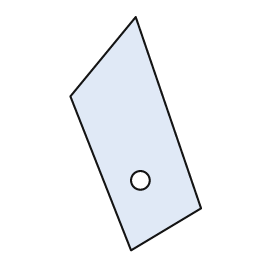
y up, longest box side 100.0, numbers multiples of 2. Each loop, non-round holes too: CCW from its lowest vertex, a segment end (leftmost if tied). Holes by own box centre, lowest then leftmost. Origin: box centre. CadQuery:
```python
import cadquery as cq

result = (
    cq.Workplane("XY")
    .moveTo(-2.0, -50.0)
    .lineTo(28.0, -32.0)
    .lineTo(0.0, 50.0)
    .lineTo(-28.0, 16.0)
    .close()
    .moveTo(2.0, -20.0)
    .circle(4.0)
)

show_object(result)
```